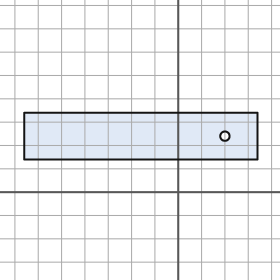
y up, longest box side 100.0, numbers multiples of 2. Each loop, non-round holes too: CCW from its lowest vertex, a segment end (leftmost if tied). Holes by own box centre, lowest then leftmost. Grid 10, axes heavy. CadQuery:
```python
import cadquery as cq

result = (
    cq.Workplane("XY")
    .moveTo(-66.0, 14.0)
    .lineTo(34.0, 14.0)
    .lineTo(34.0, 34.0)
    .lineTo(-66.0, 34.0)
    .close()
    .moveTo(20.0, 24.0)
    .circle(2.0)
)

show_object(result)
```